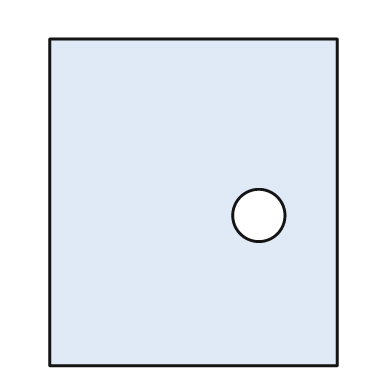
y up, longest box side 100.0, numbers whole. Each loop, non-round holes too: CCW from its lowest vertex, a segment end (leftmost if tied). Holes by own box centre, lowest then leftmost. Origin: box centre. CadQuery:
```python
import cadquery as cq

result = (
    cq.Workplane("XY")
    .moveTo(-44.0, -50.0)
    .lineTo(44.0, -50.0)
    .lineTo(44.0, 50.0)
    .lineTo(-44.0, 50.0)
    .close()
    .moveTo(20.0, -4.0)
    .circle(8.0)
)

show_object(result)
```